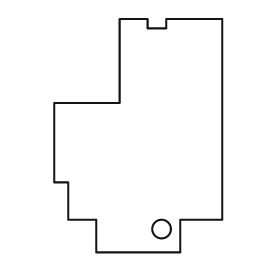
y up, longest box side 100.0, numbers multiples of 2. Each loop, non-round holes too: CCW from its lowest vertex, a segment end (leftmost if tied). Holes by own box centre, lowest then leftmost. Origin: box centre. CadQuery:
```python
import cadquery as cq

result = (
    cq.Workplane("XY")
    .moveTo(-18.0, -50.0)
    .lineTo(18.0, -50.0)
    .lineTo(18.0, -36.0)
    .lineTo(36.0, -36.0)
    .lineTo(36.0, 50.0)
    .lineTo(12.0, 50.0)
    .lineTo(12.0, 46.0)
    .lineTo(4.0, 46.0)
    .lineTo(4.0, 50.0)
    .lineTo(-8.0, 50.0)
    .lineTo(-8.0, 14.0)
    .lineTo(-36.0, 14.0)
    .lineTo(-36.0, -20.0)
    .lineTo(-30.0, -20.0)
    .lineTo(-30.0, -36.0)
    .lineTo(-18.0, -36.0)
    .close()
    .moveTo(10.0, -40.0)
    .circle(4.0)
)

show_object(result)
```